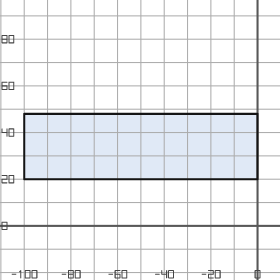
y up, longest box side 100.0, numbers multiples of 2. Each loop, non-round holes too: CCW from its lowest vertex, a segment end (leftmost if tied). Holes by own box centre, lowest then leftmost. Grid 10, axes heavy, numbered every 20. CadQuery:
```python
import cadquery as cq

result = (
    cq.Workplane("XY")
    .moveTo(-100.0, 20.0)
    .lineTo(0.0, 20.0)
    .lineTo(0.0, 48.0)
    .lineTo(-100.0, 48.0)
    .close()
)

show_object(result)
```